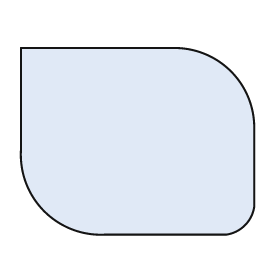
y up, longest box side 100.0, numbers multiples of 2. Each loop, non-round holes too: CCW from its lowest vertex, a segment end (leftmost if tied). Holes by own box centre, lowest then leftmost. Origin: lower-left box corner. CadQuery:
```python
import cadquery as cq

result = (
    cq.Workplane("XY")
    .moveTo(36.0, 0.0)
    .lineTo(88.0, 0.0)
    .threePointArc((96.0, 4.0), (100.0, 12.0))
    .lineTo(100.0, 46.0)
    .threePointArc((90.0, 70.0), (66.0, 80.0))
    .lineTo(0.0, 80.0)
    .lineTo(0.0, 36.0)
    .threePointArc((10.0, 10.0), (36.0, 0.0))
    .close()
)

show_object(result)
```